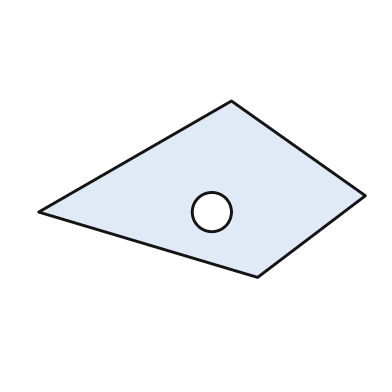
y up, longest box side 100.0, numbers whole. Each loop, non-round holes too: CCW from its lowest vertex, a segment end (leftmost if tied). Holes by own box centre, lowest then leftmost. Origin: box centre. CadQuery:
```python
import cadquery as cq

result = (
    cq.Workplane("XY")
    .moveTo(17.0, -27.0)
    .lineTo(50.0, -2.0)
    .lineTo(9.0, 27.0)
    .lineTo(-50.0, -7.0)
    .close()
    .moveTo(3.0, -7.0)
    .circle(6.0)
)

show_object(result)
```